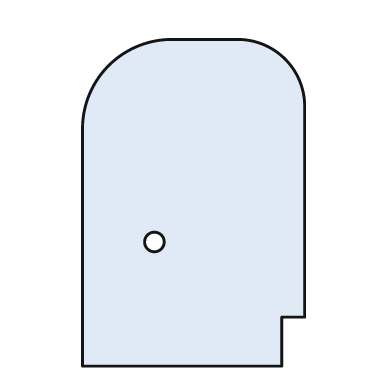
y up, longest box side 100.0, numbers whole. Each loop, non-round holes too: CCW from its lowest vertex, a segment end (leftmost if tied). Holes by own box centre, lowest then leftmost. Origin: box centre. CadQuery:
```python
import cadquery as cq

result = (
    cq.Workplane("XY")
    .moveTo(-34.0, -50.0)
    .lineTo(27.0, -50.0)
    .lineTo(27.0, -35.0)
    .lineTo(34.0, -35.0)
    .lineTo(34.0, 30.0)
    .threePointArc((28.0, 44.0), (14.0, 50.0))
    .lineTo(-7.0, 50.0)
    .threePointArc((-26.0, 42.0), (-34.0, 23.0))
    .close()
    .moveTo(-12.0, -12.0)
    .circle(3.0)
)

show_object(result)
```